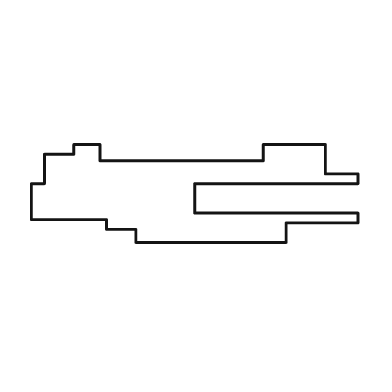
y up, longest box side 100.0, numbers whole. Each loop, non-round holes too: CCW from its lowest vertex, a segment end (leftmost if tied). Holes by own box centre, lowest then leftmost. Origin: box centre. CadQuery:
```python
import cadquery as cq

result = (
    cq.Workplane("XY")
    .moveTo(-18.0, -15.0)
    .lineTo(28.0, -15.0)
    .lineTo(28.0, -9.0)
    .lineTo(50.0, -9.0)
    .lineTo(50.0, -6.0)
    .lineTo(0.0, -6.0)
    .lineTo(0.0, 3.0)
    .lineTo(50.0, 3.0)
    .lineTo(50.0, 6.0)
    .lineTo(40.0, 6.0)
    .lineTo(40.0, 15.0)
    .lineTo(21.0, 15.0)
    .lineTo(21.0, 10.0)
    .lineTo(-29.0, 10.0)
    .lineTo(-29.0, 15.0)
    .lineTo(-37.0, 15.0)
    .lineTo(-37.0, 12.0)
    .lineTo(-46.0, 12.0)
    .lineTo(-46.0, 3.0)
    .lineTo(-50.0, 3.0)
    .lineTo(-50.0, -8.0)
    .lineTo(-27.0, -8.0)
    .lineTo(-27.0, -11.0)
    .lineTo(-18.0, -11.0)
    .close()
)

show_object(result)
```